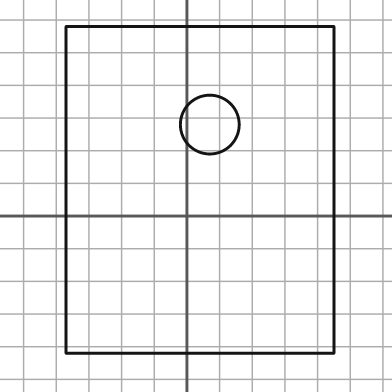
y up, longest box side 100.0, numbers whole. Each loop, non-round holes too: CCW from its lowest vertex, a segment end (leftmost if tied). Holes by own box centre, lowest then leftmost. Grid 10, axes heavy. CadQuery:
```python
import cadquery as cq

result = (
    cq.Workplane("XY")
    .moveTo(-37.0, -42.0)
    .lineTo(45.0, -42.0)
    .lineTo(45.0, 58.0)
    .lineTo(-37.0, 58.0)
    .close()
    .moveTo(7.0, 28.0)
    .circle(9.0)
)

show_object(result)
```